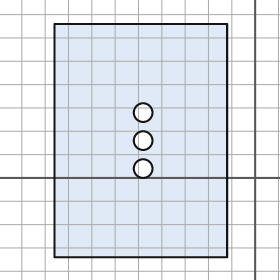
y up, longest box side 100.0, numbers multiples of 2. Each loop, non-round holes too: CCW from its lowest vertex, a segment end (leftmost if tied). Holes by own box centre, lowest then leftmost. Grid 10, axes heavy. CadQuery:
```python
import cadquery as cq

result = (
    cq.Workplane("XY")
    .moveTo(-86.0, -34.0)
    .lineTo(-12.0, -34.0)
    .lineTo(-12.0, 66.0)
    .lineTo(-86.0, 66.0)
    .close()
    .moveTo(-48.0, 4.0)
    .circle(4.0)
    .moveTo(-48.0, 16.0)
    .circle(4.0)
    .moveTo(-48.0, 28.0)
    .circle(4.0)
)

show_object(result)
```